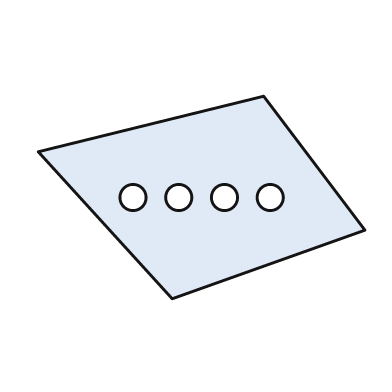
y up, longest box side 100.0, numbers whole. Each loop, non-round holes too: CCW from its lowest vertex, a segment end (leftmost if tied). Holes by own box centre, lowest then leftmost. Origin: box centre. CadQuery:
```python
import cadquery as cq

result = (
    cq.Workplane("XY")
    .moveTo(-9.0, -31.0)
    .lineTo(50.0, -10.0)
    .lineTo(19.0, 31.0)
    .lineTo(-50.0, 14.0)
    .close()
    .moveTo(-21.0, 0.0)
    .circle(4.0)
    .moveTo(-7.0, 0.0)
    .circle(4.0)
    .moveTo(7.0, 0.0)
    .circle(4.0)
    .moveTo(21.0, 0.0)
    .circle(4.0)
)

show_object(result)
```